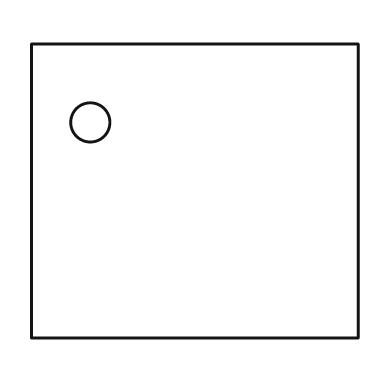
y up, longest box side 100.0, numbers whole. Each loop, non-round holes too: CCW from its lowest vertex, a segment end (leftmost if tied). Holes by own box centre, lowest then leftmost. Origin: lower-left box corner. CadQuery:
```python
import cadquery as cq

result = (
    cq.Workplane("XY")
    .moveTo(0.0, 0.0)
    .lineTo(100.0, 0.0)
    .lineTo(100.0, 90.0)
    .lineTo(0.0, 90.0)
    .close()
    .moveTo(18.0, 66.0)
    .circle(6.0)
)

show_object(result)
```